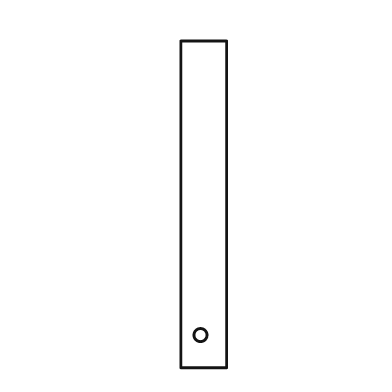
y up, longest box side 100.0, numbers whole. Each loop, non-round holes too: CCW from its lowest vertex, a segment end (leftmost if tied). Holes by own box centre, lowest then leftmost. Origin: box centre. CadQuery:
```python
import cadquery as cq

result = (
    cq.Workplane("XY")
    .moveTo(-7.0, -50.0)
    .lineTo(7.0, -50.0)
    .lineTo(7.0, 50.0)
    .lineTo(-7.0, 50.0)
    .close()
    .moveTo(-1.0, -40.0)
    .circle(2.0)
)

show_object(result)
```